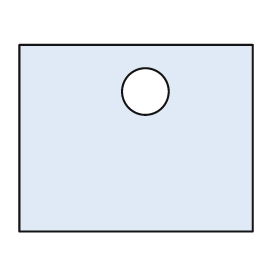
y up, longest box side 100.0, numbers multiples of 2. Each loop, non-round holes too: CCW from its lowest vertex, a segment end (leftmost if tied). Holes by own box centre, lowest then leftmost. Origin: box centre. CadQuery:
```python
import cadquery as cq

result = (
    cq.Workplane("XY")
    .moveTo(-50.0, -40.0)
    .lineTo(50.0, -40.0)
    .lineTo(50.0, 40.0)
    .lineTo(-50.0, 40.0)
    .close()
    .moveTo(4.0, 20.0)
    .circle(10.0)
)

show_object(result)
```